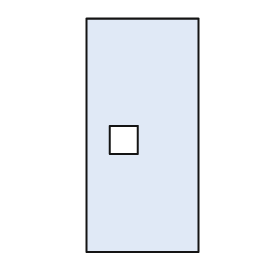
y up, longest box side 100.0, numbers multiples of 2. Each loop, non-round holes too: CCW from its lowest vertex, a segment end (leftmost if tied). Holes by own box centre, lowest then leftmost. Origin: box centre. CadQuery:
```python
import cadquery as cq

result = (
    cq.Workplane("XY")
    .moveTo(-24.0, -50.0)
    .lineTo(24.0, -50.0)
    .lineTo(24.0, 50.0)
    .lineTo(-24.0, 50.0)
    .close()
    .moveTo(-14.0, -8.0)
    .lineTo(-2.0, -8.0)
    .lineTo(-2.0, 4.0)
    .lineTo(-14.0, 4.0)
    .close()
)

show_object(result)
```